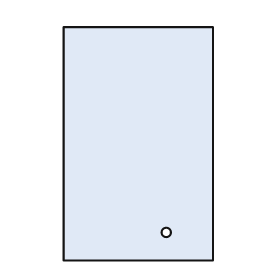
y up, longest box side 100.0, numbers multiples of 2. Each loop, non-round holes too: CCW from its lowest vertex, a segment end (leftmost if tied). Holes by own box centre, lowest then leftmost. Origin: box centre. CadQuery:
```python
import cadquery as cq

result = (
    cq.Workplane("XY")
    .moveTo(-32.0, -50.0)
    .lineTo(32.0, -50.0)
    .lineTo(32.0, 50.0)
    .lineTo(-32.0, 50.0)
    .close()
    .moveTo(12.0, -38.0)
    .circle(2.0)
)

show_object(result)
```